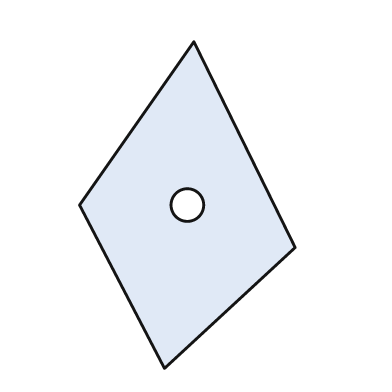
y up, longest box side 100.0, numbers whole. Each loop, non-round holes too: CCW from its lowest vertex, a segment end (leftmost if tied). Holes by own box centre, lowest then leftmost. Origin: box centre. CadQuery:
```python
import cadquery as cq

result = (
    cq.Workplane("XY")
    .moveTo(-7.0, -50.0)
    .lineTo(33.0, -13.0)
    .lineTo(2.0, 50.0)
    .lineTo(-33.0, 0.0)
    .close()
    .moveTo(0.0, 0.0)
    .circle(5.0)
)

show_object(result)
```